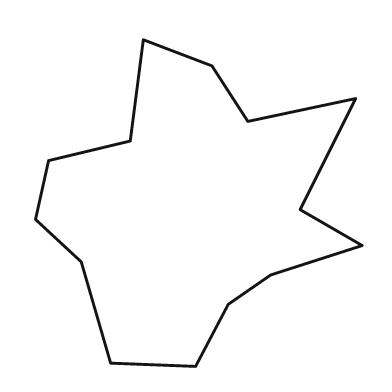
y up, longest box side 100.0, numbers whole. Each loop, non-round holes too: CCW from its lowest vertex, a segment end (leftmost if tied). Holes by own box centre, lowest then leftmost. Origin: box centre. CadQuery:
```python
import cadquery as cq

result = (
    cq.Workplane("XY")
    .moveTo(-1.0, -50.0)
    .lineTo(9.0, -31.0)
    .lineTo(22.0, -22.0)
    .lineTo(50.0, -13.0)
    .lineTo(31.0, -2.0)
    .lineTo(48.0, 32.0)
    .lineTo(15.0, 25.0)
    .lineTo(4.0, 42.0)
    .lineTo(-17.0, 50.0)
    .lineTo(-21.0, 19.0)
    .lineTo(-46.0, 13.0)
    .lineTo(-50.0, -5.0)
    .lineTo(-36.0, -18.0)
    .lineTo(-27.0, -49.0)
    .close()
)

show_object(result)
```